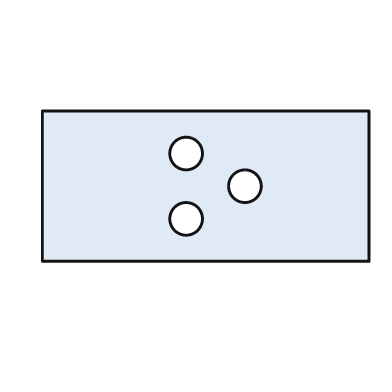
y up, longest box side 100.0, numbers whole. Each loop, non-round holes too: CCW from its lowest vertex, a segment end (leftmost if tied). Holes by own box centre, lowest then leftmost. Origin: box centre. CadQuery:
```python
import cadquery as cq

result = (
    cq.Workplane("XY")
    .moveTo(-50.0, -23.0)
    .lineTo(50.0, -23.0)
    .lineTo(50.0, 23.0)
    .lineTo(-50.0, 23.0)
    .close()
    .moveTo(-6.0, -10.0)
    .circle(5.0)
    .moveTo(12.0, 0.0)
    .circle(5.0)
    .moveTo(-6.0, 10.0)
    .circle(5.0)
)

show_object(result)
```